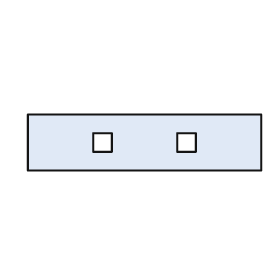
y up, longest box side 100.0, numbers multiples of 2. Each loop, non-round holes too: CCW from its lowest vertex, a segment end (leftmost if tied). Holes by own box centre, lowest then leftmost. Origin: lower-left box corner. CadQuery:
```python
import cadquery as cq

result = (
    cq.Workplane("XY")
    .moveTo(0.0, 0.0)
    .lineTo(100.0, 0.0)
    .lineTo(100.0, 24.0)
    .lineTo(0.0, 24.0)
    .close()
    .moveTo(28.0, 8.0)
    .lineTo(36.0, 8.0)
    .lineTo(36.0, 16.0)
    .lineTo(28.0, 16.0)
    .close()
    .moveTo(64.0, 8.0)
    .lineTo(72.0, 8.0)
    .lineTo(72.0, 16.0)
    .lineTo(64.0, 16.0)
    .close()
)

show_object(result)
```